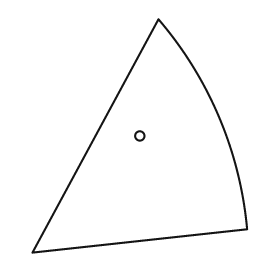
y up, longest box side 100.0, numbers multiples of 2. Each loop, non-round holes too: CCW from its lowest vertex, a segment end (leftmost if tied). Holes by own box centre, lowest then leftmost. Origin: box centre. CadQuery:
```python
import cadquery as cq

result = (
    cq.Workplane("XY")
    .moveTo(-46.0, -50.0)
    .lineTo(46.0, -40.0)
    .threePointArc((34.0, 8.0), (8.0, 50.0))
    .close()
    .moveTo(0.0, 0.0)
    .circle(2.0)
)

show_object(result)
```